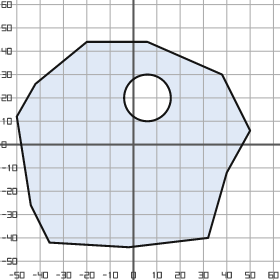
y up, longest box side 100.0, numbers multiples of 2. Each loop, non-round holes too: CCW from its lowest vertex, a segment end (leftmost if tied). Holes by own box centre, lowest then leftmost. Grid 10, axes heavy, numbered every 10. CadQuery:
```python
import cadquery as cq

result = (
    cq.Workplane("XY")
    .moveTo(-2.0, -44.0)
    .lineTo(32.0, -40.0)
    .lineTo(40.0, -12.0)
    .lineTo(50.0, 6.0)
    .lineTo(38.0, 30.0)
    .lineTo(6.0, 44.0)
    .lineTo(-20.0, 44.0)
    .lineTo(-42.0, 26.0)
    .lineTo(-50.0, 12.0)
    .lineTo(-44.0, -26.0)
    .lineTo(-36.0, -42.0)
    .close()
    .moveTo(6.0, 20.0)
    .circle(10.0)
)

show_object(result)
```